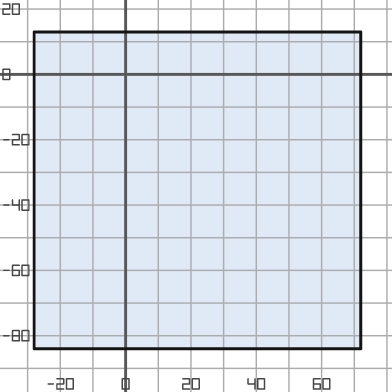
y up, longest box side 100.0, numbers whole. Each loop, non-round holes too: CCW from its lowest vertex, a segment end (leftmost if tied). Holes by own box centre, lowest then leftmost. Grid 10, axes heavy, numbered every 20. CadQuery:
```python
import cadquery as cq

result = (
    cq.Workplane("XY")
    .moveTo(-28.0, -84.0)
    .lineTo(72.0, -84.0)
    .lineTo(72.0, 13.0)
    .lineTo(-28.0, 13.0)
    .close()
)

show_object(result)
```